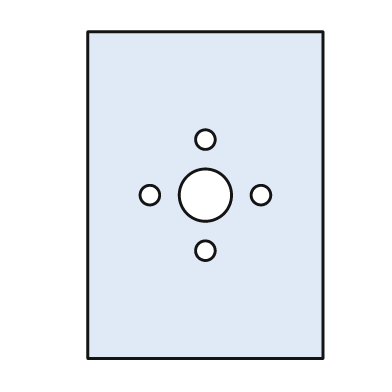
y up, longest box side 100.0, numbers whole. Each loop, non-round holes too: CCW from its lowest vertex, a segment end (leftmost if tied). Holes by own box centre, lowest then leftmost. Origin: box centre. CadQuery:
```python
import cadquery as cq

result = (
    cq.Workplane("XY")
    .moveTo(-36.0, -50.0)
    .lineTo(36.0, -50.0)
    .lineTo(36.0, 50.0)
    .lineTo(-36.0, 50.0)
    .close()
    .moveTo(0.0, -17.0)
    .circle(3.0)
    .moveTo(-17.0, 0.0)
    .circle(3.0)
    .moveTo(0.0, 0.0)
    .circle(8.0)
    .moveTo(17.0, 0.0)
    .circle(3.0)
    .moveTo(0.0, 17.0)
    .circle(3.0)
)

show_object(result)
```